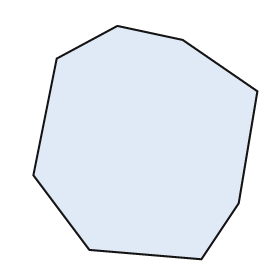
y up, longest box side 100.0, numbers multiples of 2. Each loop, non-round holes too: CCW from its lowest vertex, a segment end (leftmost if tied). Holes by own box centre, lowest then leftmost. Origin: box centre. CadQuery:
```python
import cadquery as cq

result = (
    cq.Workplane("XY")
    .moveTo(24.0, -50.0)
    .lineTo(40.0, -26.0)
    .lineTo(48.0, 22.0)
    .lineTo(16.0, 44.0)
    .lineTo(-12.0, 50.0)
    .lineTo(-38.0, 36.0)
    .lineTo(-48.0, -14.0)
    .lineTo(-24.0, -46.0)
    .close()
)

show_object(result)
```